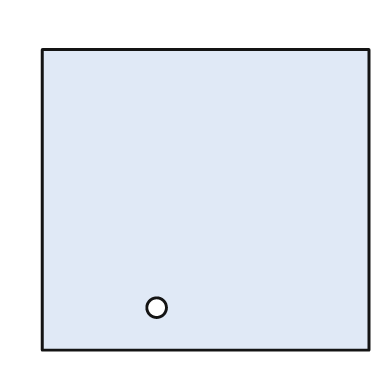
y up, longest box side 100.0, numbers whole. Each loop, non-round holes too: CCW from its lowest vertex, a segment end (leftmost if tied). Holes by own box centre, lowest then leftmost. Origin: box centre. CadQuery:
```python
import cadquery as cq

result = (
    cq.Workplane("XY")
    .moveTo(-50.0, -46.0)
    .lineTo(50.0, -46.0)
    .lineTo(50.0, 46.0)
    .lineTo(-50.0, 46.0)
    .close()
    .moveTo(-15.0, -33.0)
    .circle(3.0)
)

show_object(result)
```